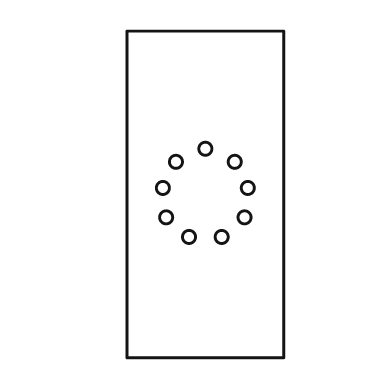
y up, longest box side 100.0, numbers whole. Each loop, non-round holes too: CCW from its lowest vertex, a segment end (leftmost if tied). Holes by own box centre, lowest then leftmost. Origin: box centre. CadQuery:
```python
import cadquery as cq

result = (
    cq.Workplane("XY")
    .moveTo(-24.0, -50.0)
    .lineTo(24.0, -50.0)
    .lineTo(24.0, 50.0)
    .lineTo(-24.0, 50.0)
    .close()
    .moveTo(-5.0, -13.0)
    .circle(2.0)
    .moveTo(5.0, -13.0)
    .circle(2.0)
    .moveTo(-12.0, -7.0)
    .circle(2.0)
    .moveTo(12.0, -7.0)
    .circle(2.0)
    .moveTo(-13.0, 2.0)
    .circle(2.0)
    .moveTo(13.0, 2.0)
    .circle(2.0)
    .moveTo(-9.0, 10.0)
    .circle(2.0)
    .moveTo(9.0, 10.0)
    .circle(2.0)
    .moveTo(0.0, 14.0)
    .circle(2.0)
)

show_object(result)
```